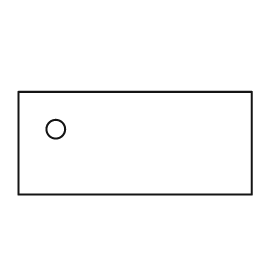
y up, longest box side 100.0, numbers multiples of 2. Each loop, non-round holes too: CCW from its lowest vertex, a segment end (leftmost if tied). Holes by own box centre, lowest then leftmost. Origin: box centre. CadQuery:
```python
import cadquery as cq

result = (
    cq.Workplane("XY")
    .moveTo(-50.0, -22.0)
    .lineTo(50.0, -22.0)
    .lineTo(50.0, 22.0)
    .lineTo(-50.0, 22.0)
    .close()
    .moveTo(-34.0, 6.0)
    .circle(4.0)
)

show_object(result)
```